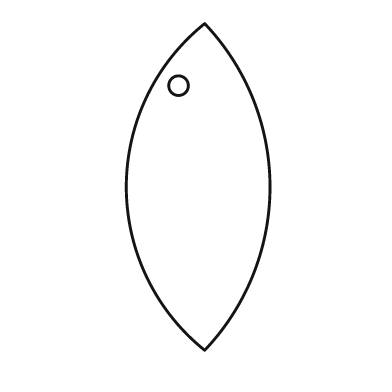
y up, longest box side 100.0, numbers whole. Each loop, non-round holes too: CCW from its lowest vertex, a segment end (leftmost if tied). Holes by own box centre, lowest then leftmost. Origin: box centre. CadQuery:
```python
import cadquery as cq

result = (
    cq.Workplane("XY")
    .moveTo(2.0, -50.0)
    .threePointArc((22.0, 0.0), (2.0, 50.0))
    .threePointArc((-22.0, 0.0), (2.0, -50.0))
    .close()
    .moveTo(-6.0, 31.0)
    .circle(3.0)
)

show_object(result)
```